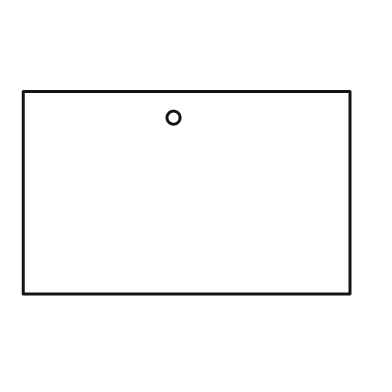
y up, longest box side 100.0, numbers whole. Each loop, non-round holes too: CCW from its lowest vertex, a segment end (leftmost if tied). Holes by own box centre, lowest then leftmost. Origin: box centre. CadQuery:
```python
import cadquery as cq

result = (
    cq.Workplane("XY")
    .moveTo(-50.0, -31.0)
    .lineTo(50.0, -31.0)
    .lineTo(50.0, 31.0)
    .lineTo(-50.0, 31.0)
    .close()
    .moveTo(-4.0, 23.0)
    .circle(2.0)
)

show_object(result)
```